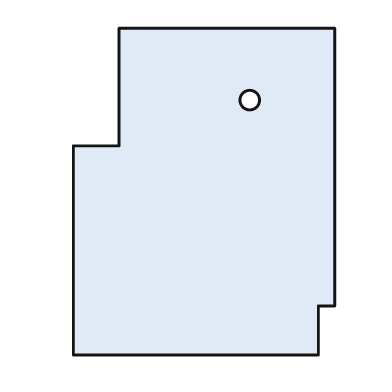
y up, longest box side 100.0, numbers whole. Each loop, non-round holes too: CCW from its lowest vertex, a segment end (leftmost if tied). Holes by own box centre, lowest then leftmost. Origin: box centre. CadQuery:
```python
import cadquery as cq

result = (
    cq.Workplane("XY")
    .moveTo(-40.0, -50.0)
    .lineTo(35.0, -50.0)
    .lineTo(35.0, -35.0)
    .lineTo(40.0, -35.0)
    .lineTo(40.0, 50.0)
    .lineTo(-26.0, 50.0)
    .lineTo(-26.0, 14.0)
    .lineTo(-40.0, 14.0)
    .close()
    .moveTo(14.0, 28.0)
    .circle(3.0)
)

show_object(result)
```